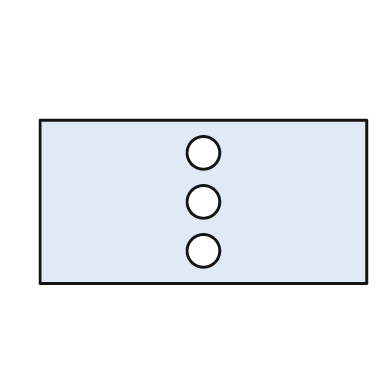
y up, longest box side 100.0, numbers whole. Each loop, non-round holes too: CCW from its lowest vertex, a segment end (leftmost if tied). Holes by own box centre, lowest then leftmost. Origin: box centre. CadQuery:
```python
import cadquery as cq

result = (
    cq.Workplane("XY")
    .moveTo(-50.0, -25.0)
    .lineTo(50.0, -25.0)
    .lineTo(50.0, 25.0)
    .lineTo(-50.0, 25.0)
    .close()
    .moveTo(0.0, -15.0)
    .circle(5.0)
    .moveTo(0.0, 0.0)
    .circle(5.0)
    .moveTo(0.0, 15.0)
    .circle(5.0)
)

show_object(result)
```